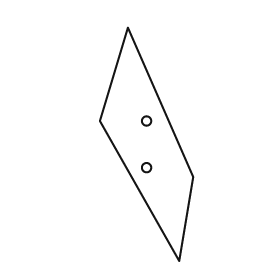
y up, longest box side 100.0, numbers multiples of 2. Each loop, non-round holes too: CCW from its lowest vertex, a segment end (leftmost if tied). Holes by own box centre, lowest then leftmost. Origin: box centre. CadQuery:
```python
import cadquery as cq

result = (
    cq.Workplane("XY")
    .moveTo(14.0, -50.0)
    .lineTo(20.0, -14.0)
    .lineTo(-8.0, 50.0)
    .lineTo(-20.0, 10.0)
    .close()
    .moveTo(0.0, -10.0)
    .circle(2.0)
    .moveTo(0.0, 10.0)
    .circle(2.0)
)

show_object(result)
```